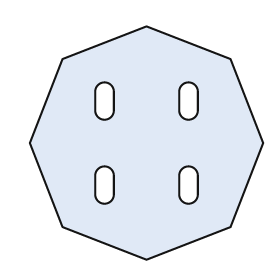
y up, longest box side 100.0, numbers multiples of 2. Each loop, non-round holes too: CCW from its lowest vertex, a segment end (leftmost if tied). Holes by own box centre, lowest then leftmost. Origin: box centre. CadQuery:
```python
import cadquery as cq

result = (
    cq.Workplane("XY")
    .moveTo(0.0, -50.0)
    .lineTo(36.0, -36.0)
    .lineTo(50.0, 0.0)
    .lineTo(36.0, 36.0)
    .lineTo(0.0, 50.0)
    .lineTo(-36.0, 36.0)
    .lineTo(-50.0, 0.0)
    .lineTo(-36.0, -36.0)
    .close()
    .moveTo(-22.0, -22.0)
    .threePointArc((-18.0, -26.0), (-14.0, -22.0))
    .lineTo(-14.0, -14.0)
    .threePointArc((-18.0, -10.0), (-22.0, -14.0))
    .close()
    .moveTo(14.0, -22.0)
    .threePointArc((18.0, -26.0), (22.0, -22.0))
    .lineTo(22.0, -14.0)
    .threePointArc((18.0, -10.0), (14.0, -14.0))
    .close()
    .moveTo(-22.0, 14.0)
    .threePointArc((-18.0, 10.0), (-14.0, 14.0))
    .lineTo(-14.0, 22.0)
    .threePointArc((-18.0, 26.0), (-22.0, 22.0))
    .close()
    .moveTo(14.0, 14.0)
    .threePointArc((18.0, 10.0), (22.0, 14.0))
    .lineTo(22.0, 22.0)
    .threePointArc((18.0, 26.0), (14.0, 22.0))
    .close()
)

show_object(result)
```